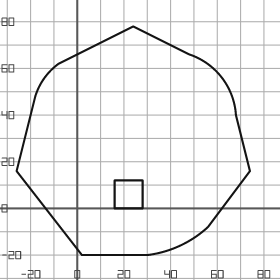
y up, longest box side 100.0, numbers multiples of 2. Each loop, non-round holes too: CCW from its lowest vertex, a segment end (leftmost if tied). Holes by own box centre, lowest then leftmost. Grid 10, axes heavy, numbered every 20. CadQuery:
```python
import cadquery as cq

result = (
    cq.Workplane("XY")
    .moveTo(2.0, -20.0)
    .lineTo(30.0, -20.0)
    .threePointArc((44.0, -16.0), (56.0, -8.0))
    .lineTo(74.0, 16.0)
    .lineTo(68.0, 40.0)
    .threePointArc((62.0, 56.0), (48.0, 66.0))
    .lineTo(24.0, 78.0)
    .lineTo(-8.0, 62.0)
    .threePointArc((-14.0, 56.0), (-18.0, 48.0))
    .lineTo(-26.0, 16.0)
    .close()
    .moveTo(16.0, 0.0)
    .lineTo(28.0, 0.0)
    .lineTo(28.0, 12.0)
    .lineTo(16.0, 12.0)
    .close()
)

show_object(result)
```